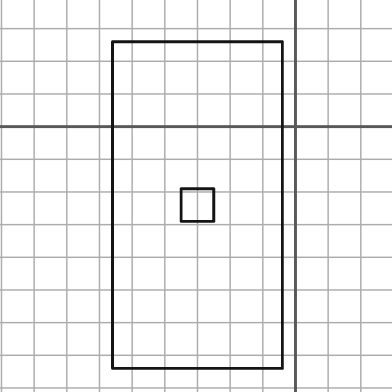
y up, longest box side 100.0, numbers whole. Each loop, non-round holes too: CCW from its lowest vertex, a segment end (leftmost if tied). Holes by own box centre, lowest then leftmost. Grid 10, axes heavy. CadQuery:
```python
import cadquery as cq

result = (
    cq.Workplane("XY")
    .moveTo(-56.0, -74.0)
    .lineTo(-4.0, -74.0)
    .lineTo(-4.0, 26.0)
    .lineTo(-56.0, 26.0)
    .close()
    .moveTo(-35.0, -29.0)
    .lineTo(-25.0, -29.0)
    .lineTo(-25.0, -19.0)
    .lineTo(-35.0, -19.0)
    .close()
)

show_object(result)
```